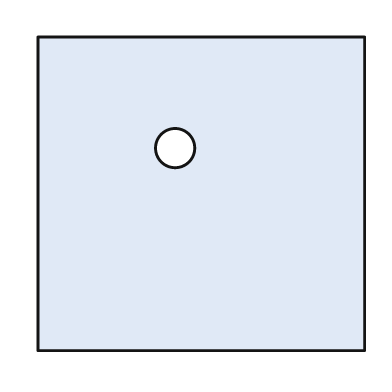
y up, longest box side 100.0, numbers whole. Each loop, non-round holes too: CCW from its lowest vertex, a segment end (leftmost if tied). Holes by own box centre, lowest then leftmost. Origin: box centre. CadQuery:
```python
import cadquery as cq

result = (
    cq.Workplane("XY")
    .moveTo(-50.0, -48.0)
    .lineTo(50.0, -48.0)
    .lineTo(50.0, 48.0)
    .lineTo(-50.0, 48.0)
    .close()
    .moveTo(-8.0, 14.0)
    .circle(6.0)
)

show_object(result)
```